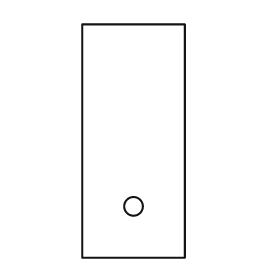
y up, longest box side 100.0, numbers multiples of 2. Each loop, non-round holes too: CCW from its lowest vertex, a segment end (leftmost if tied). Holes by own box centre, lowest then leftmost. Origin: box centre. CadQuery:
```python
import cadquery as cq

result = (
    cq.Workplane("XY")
    .moveTo(-22.0, -50.0)
    .lineTo(22.0, -50.0)
    .lineTo(22.0, 50.0)
    .lineTo(-22.0, 50.0)
    .close()
    .moveTo(0.0, -28.0)
    .circle(4.0)
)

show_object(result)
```